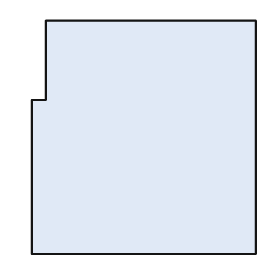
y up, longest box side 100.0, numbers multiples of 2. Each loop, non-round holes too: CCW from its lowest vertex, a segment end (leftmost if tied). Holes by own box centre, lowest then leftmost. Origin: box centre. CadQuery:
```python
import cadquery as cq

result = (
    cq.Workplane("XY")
    .moveTo(-48.0, -50.0)
    .lineTo(48.0, -50.0)
    .lineTo(48.0, 50.0)
    .lineTo(-42.0, 50.0)
    .lineTo(-42.0, 16.0)
    .lineTo(-48.0, 16.0)
    .close()
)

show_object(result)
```